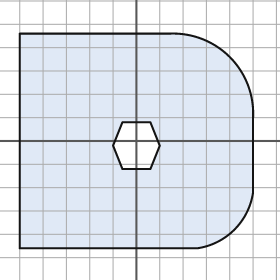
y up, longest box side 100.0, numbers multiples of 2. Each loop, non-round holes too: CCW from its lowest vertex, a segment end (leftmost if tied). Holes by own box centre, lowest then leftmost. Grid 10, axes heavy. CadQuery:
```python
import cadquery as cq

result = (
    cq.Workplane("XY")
    .moveTo(-50.0, -46.0)
    .lineTo(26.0, -46.0)
    .threePointArc((42.0, -38.0), (50.0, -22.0))
    .lineTo(50.0, 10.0)
    .threePointArc((40.0, 36.0), (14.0, 46.0))
    .lineTo(-50.0, 46.0)
    .close()
    .moveTo(-6.0, -12.0)
    .lineTo(6.0, -12.0)
    .lineTo(10.0, -2.0)
    .lineTo(6.0, 8.0)
    .lineTo(-6.0, 8.0)
    .lineTo(-10.0, -2.0)
    .close()
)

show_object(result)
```